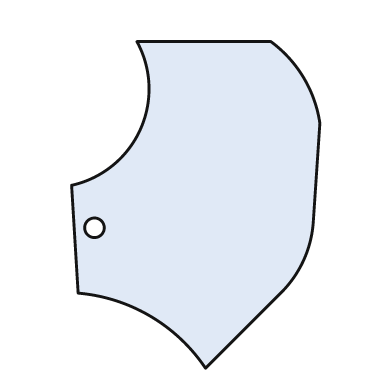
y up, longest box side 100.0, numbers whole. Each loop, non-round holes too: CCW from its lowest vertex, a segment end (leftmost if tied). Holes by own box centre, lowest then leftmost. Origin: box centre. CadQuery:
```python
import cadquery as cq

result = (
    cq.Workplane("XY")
    .moveTo(3.0, -50.0)
    .lineTo(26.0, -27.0)
    .threePointArc((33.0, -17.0), (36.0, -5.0))
    .lineTo(38.0, 25.0)
    .threePointArc((33.0, 39.0), (23.0, 50.0))
    .lineTo(-18.0, 50.0)
    .threePointArc((-17.0, 23.0), (-38.0, 6.0))
    .lineTo(-36.0, -27.0)
    .threePointArc((-14.0, -34.0), (3.0, -50.0))
    .close()
    .moveTo(-31.0, -7.0)
    .circle(3.0)
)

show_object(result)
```